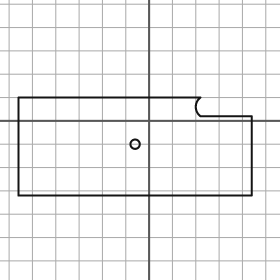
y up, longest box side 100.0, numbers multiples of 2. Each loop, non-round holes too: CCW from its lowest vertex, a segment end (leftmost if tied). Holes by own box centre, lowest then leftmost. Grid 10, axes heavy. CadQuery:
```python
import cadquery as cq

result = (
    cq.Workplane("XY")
    .moveTo(-56.0, -32.0)
    .lineTo(44.0, -32.0)
    .lineTo(44.0, 2.0)
    .lineTo(22.0, 2.0)
    .threePointArc((20.0, 6.0), (22.0, 10.0))
    .lineTo(-56.0, 10.0)
    .close()
    .moveTo(-6.0, -10.0)
    .circle(2.0)
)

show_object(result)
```